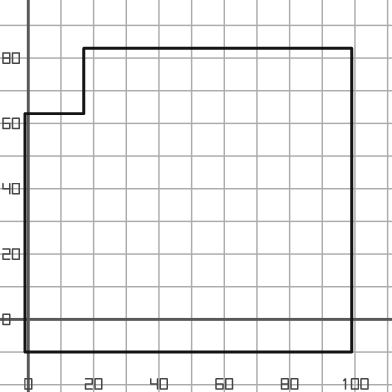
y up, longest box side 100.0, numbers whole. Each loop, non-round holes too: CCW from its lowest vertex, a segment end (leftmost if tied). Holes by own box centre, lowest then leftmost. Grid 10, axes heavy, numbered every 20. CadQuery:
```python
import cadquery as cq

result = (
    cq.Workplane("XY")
    .moveTo(-1.0, -10.0)
    .lineTo(99.0, -10.0)
    .lineTo(99.0, 83.0)
    .lineTo(17.0, 83.0)
    .lineTo(17.0, 63.0)
    .lineTo(-1.0, 63.0)
    .close()
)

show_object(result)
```